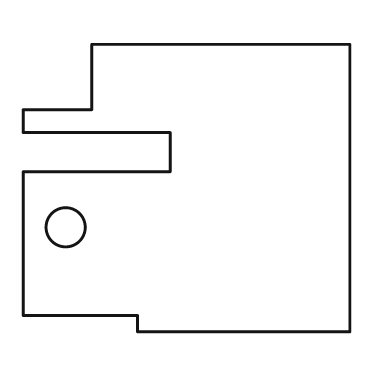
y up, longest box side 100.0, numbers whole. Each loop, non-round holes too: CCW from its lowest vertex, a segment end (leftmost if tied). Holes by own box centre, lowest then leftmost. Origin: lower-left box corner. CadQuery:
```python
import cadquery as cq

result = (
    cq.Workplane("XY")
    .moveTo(35.0, 0.0)
    .lineTo(100.0, 0.0)
    .lineTo(100.0, 88.0)
    .lineTo(21.0, 88.0)
    .lineTo(21.0, 68.0)
    .lineTo(0.0, 68.0)
    .lineTo(0.0, 61.0)
    .lineTo(45.0, 61.0)
    .lineTo(45.0, 49.0)
    .lineTo(0.0, 49.0)
    .lineTo(0.0, 5.0)
    .lineTo(35.0, 5.0)
    .close()
    .moveTo(13.0, 32.0)
    .circle(6.0)
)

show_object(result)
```